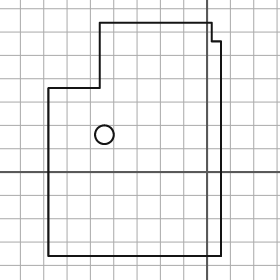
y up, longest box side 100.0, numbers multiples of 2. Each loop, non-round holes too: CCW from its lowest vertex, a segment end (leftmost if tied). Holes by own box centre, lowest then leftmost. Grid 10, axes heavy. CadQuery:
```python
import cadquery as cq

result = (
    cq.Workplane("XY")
    .moveTo(-68.0, -36.0)
    .lineTo(6.0, -36.0)
    .lineTo(6.0, 56.0)
    .lineTo(2.0, 56.0)
    .lineTo(2.0, 64.0)
    .lineTo(-46.0, 64.0)
    .lineTo(-46.0, 36.0)
    .lineTo(-68.0, 36.0)
    .close()
    .moveTo(-44.0, 16.0)
    .circle(4.0)
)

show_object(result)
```